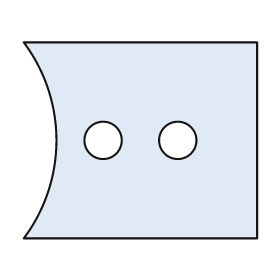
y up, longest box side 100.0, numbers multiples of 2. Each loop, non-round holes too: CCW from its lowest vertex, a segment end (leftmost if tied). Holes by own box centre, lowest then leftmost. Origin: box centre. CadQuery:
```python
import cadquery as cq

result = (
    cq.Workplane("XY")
    .moveTo(-50.0, -42.0)
    .lineTo(50.0, -42.0)
    .lineTo(50.0, 42.0)
    .lineTo(-50.0, 42.0)
    .threePointArc((-36.0, 0.0), (-50.0, -42.0))
    .close()
    .moveTo(-16.0, 0.0)
    .circle(8.0)
    .moveTo(16.0, 0.0)
    .circle(8.0)
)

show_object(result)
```